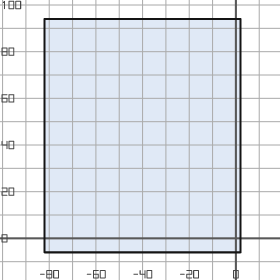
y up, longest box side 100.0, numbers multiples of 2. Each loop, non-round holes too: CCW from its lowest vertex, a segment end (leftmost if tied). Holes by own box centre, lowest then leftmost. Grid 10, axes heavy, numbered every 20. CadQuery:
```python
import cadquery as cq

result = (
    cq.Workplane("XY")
    .moveTo(-82.0, -6.0)
    .lineTo(2.0, -6.0)
    .lineTo(2.0, 94.0)
    .lineTo(-82.0, 94.0)
    .close()
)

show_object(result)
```